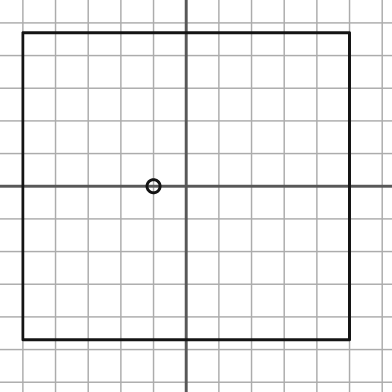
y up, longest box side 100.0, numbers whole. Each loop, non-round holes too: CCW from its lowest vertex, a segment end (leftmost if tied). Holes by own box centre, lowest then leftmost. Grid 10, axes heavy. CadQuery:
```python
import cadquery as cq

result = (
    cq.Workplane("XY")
    .moveTo(-50.0, -47.0)
    .lineTo(50.0, -47.0)
    .lineTo(50.0, 47.0)
    .lineTo(-50.0, 47.0)
    .close()
    .moveTo(-10.0, 0.0)
    .circle(2.0)
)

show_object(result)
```